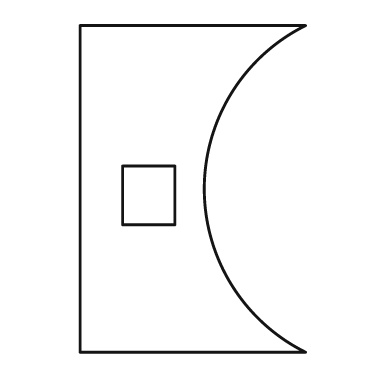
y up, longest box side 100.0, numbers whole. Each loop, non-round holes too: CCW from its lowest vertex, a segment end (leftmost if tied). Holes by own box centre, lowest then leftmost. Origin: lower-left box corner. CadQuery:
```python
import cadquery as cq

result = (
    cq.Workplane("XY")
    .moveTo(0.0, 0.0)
    .lineTo(69.0, 0.0)
    .threePointArc((38.0, 50.0), (69.0, 100.0))
    .lineTo(0.0, 100.0)
    .close()
    .moveTo(13.0, 39.0)
    .lineTo(29.0, 39.0)
    .lineTo(29.0, 57.0)
    .lineTo(13.0, 57.0)
    .close()
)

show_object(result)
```